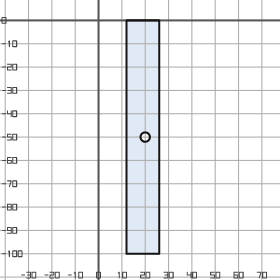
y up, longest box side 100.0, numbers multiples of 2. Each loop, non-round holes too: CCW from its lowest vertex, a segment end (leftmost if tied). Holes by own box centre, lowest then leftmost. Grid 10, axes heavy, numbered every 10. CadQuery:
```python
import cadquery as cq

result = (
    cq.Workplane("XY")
    .moveTo(12.0, -100.0)
    .lineTo(26.0, -100.0)
    .lineTo(26.0, 0.0)
    .lineTo(12.0, 0.0)
    .close()
    .moveTo(20.0, -50.0)
    .circle(2.0)
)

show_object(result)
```